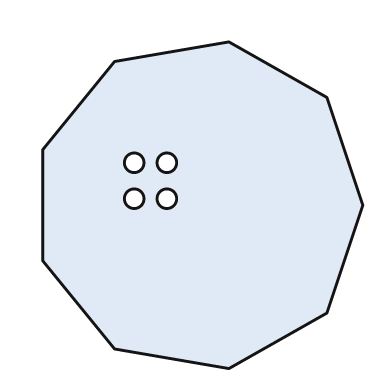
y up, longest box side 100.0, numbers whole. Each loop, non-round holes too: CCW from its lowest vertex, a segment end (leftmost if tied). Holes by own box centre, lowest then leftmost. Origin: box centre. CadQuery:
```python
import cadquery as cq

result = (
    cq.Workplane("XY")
    .moveTo(8.0, -50.0)
    .lineTo(38.0, -33.0)
    .lineTo(49.0, 0.0)
    .lineTo(38.0, 33.0)
    .lineTo(8.0, 50.0)
    .lineTo(-27.0, 44.0)
    .lineTo(-49.0, 17.0)
    .lineTo(-49.0, -17.0)
    .lineTo(-27.0, -44.0)
    .close()
    .moveTo(-21.0, 2.0)
    .circle(3.0)
    .moveTo(-11.0, 2.0)
    .circle(3.0)
    .moveTo(-21.0, 13.0)
    .circle(3.0)
    .moveTo(-11.0, 13.0)
    .circle(3.0)
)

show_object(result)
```